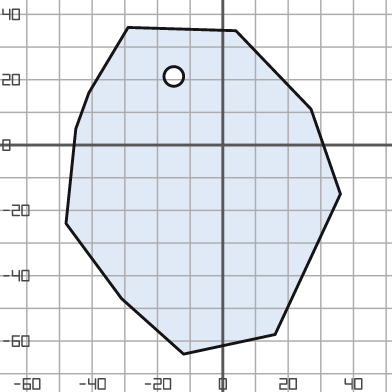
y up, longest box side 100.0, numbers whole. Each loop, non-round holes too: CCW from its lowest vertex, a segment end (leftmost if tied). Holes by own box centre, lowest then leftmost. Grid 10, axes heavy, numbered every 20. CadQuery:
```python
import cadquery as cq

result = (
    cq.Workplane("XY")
    .moveTo(-12.0, -64.0)
    .lineTo(16.0, -58.0)
    .lineTo(36.0, -15.0)
    .lineTo(27.0, 11.0)
    .lineTo(4.0, 35.0)
    .lineTo(-29.0, 36.0)
    .lineTo(-41.0, 16.0)
    .lineTo(-45.0, 5.0)
    .lineTo(-48.0, -24.0)
    .lineTo(-31.0, -47.0)
    .close()
    .moveTo(-15.0, 21.0)
    .circle(3.0)
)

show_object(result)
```